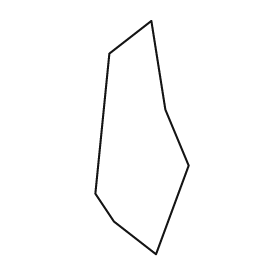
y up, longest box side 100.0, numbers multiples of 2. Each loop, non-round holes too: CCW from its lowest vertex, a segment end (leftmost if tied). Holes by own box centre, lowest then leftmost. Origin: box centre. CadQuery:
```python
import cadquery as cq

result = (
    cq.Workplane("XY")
    .moveTo(6.0, -50.0)
    .lineTo(20.0, -12.0)
    .lineTo(10.0, 12.0)
    .lineTo(4.0, 50.0)
    .lineTo(-14.0, 36.0)
    .lineTo(-20.0, -24.0)
    .lineTo(-12.0, -36.0)
    .close()
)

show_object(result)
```